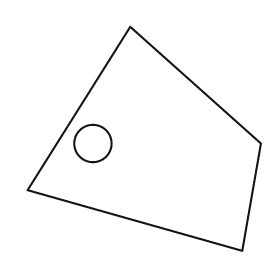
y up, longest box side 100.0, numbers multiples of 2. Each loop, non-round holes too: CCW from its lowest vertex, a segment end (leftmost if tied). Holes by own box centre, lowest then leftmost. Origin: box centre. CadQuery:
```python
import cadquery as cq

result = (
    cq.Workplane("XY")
    .moveTo(42.0, -48.0)
    .lineTo(50.0, -2.0)
    .lineTo(-6.0, 48.0)
    .lineTo(-50.0, -22.0)
    .close()
    .moveTo(-22.0, -2.0)
    .circle(8.0)
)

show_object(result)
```